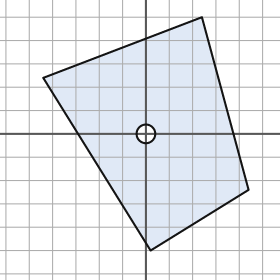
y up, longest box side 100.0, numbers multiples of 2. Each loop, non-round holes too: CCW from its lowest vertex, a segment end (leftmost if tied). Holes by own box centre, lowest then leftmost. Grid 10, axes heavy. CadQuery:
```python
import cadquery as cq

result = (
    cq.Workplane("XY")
    .moveTo(2.0, -50.0)
    .lineTo(44.0, -24.0)
    .lineTo(24.0, 50.0)
    .lineTo(-44.0, 24.0)
    .close()
    .moveTo(0.0, 0.0)
    .circle(4.0)
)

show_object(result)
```